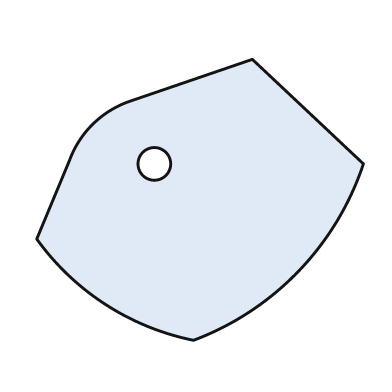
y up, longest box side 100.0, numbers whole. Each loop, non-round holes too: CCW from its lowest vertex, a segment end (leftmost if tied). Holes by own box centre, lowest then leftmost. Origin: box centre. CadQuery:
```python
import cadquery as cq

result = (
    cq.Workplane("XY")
    .moveTo(-2.0, -43.0)
    .threePointArc((30.0, -22.0), (50.0, 11.0))
    .lineTo(16.0, 43.0)
    .lineTo(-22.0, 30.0)
    .threePointArc((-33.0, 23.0), (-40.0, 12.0))
    .lineTo(-50.0, -12.0)
    .threePointArc((-29.0, -32.0), (-2.0, -43.0))
    .close()
    .moveTo(-14.0, 11.0)
    .circle(5.0)
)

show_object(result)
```